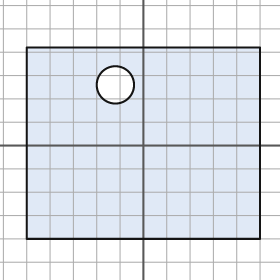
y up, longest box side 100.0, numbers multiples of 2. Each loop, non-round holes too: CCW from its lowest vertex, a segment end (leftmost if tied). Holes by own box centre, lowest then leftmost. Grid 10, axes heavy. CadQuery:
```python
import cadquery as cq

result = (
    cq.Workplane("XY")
    .moveTo(-50.0, -40.0)
    .lineTo(50.0, -40.0)
    .lineTo(50.0, 42.0)
    .lineTo(-50.0, 42.0)
    .close()
    .moveTo(-12.0, 26.0)
    .circle(8.0)
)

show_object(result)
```